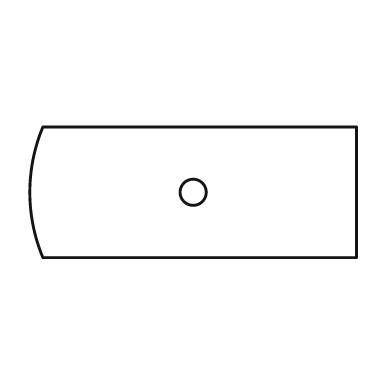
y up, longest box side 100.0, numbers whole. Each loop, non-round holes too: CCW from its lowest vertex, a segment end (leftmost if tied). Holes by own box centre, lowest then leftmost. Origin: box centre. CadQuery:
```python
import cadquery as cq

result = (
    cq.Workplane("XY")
    .moveTo(-46.0, -20.0)
    .lineTo(50.0, -20.0)
    .lineTo(50.0, 20.0)
    .lineTo(-46.0, 20.0)
    .threePointArc((-50.0, 0.0), (-46.0, -20.0))
    .close()
    .moveTo(0.0, 0.0)
    .circle(4.0)
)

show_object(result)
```